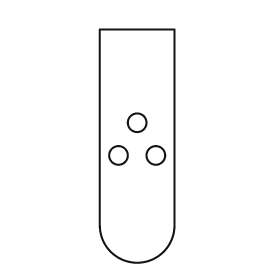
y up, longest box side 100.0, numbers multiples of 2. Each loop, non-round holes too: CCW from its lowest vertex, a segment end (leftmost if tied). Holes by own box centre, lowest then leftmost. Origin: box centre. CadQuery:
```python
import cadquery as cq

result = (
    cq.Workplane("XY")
    .moveTo(-16.0, -34.0)
    .threePointArc((0.0, -50.0), (16.0, -34.0))
    .lineTo(16.0, 50.0)
    .lineTo(-16.0, 50.0)
    .close()
    .moveTo(-8.0, -4.0)
    .circle(4.0)
    .moveTo(8.0, -4.0)
    .circle(4.0)
    .moveTo(0.0, 10.0)
    .circle(4.0)
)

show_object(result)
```